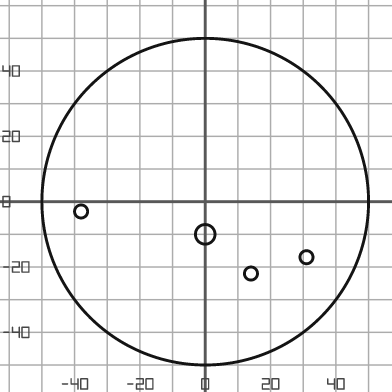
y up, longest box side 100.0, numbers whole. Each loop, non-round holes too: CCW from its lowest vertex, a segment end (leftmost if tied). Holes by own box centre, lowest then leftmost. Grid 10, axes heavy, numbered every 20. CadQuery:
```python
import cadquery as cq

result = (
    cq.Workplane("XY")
    .moveTo(0.0, 0.0)
    .circle(50.0)
    .moveTo(14.0, -22.0)
    .circle(2.0)
    .moveTo(31.0, -17.0)
    .circle(2.0)
    .moveTo(0.0, -10.0)
    .circle(3.0)
    .moveTo(-38.0, -3.0)
    .circle(2.0)
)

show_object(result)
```